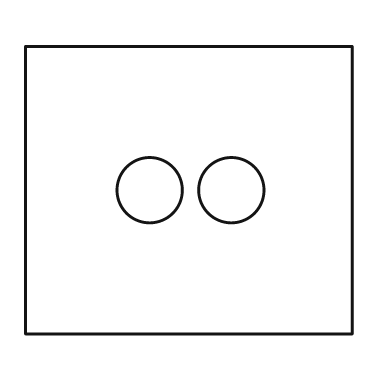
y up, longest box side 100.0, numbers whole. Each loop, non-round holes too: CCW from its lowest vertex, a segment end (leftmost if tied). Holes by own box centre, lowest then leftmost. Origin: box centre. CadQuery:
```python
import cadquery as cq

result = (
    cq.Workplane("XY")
    .moveTo(-50.0, -44.0)
    .lineTo(50.0, -44.0)
    .lineTo(50.0, 44.0)
    .lineTo(-50.0, 44.0)
    .close()
    .moveTo(-12.0, 0.0)
    .circle(10.0)
    .moveTo(13.0, 0.0)
    .circle(10.0)
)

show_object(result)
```